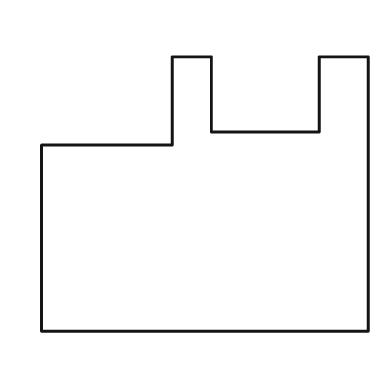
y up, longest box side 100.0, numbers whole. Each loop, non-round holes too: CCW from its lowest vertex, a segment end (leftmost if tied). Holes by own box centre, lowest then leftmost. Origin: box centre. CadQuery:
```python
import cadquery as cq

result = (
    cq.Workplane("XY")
    .moveTo(-50.0, -42.0)
    .lineTo(50.0, -42.0)
    .lineTo(50.0, 42.0)
    .lineTo(35.0, 42.0)
    .lineTo(35.0, 19.0)
    .lineTo(2.0, 19.0)
    .lineTo(2.0, 42.0)
    .lineTo(-10.0, 42.0)
    .lineTo(-10.0, 15.0)
    .lineTo(-50.0, 15.0)
    .close()
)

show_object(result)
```